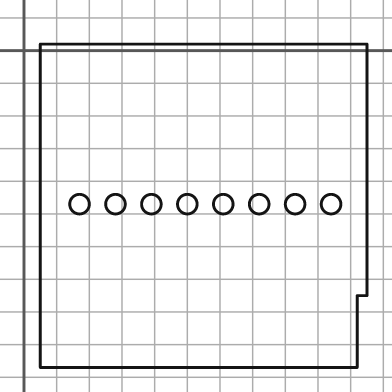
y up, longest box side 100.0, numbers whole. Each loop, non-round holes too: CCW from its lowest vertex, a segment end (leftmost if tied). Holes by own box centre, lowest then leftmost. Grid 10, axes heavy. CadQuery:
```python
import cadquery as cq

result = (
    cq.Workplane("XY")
    .moveTo(5.0, -97.0)
    .lineTo(102.0, -97.0)
    .lineTo(102.0, -75.0)
    .lineTo(105.0, -75.0)
    .lineTo(105.0, 2.0)
    .lineTo(5.0, 2.0)
    .close()
    .moveTo(17.0, -47.0)
    .circle(3.0)
    .moveTo(28.0, -47.0)
    .circle(3.0)
    .moveTo(39.0, -47.0)
    .circle(3.0)
    .moveTo(50.0, -47.0)
    .circle(3.0)
    .moveTo(61.0, -47.0)
    .circle(3.0)
    .moveTo(72.0, -47.0)
    .circle(3.0)
    .moveTo(83.0, -47.0)
    .circle(3.0)
    .moveTo(94.0, -47.0)
    .circle(3.0)
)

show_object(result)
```